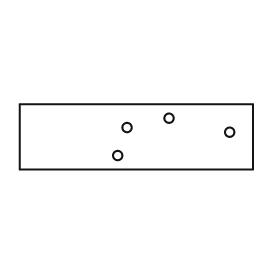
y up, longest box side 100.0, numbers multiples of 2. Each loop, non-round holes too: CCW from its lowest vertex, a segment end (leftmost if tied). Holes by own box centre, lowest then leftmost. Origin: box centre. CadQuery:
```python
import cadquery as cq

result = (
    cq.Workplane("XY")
    .moveTo(-50.0, -14.0)
    .lineTo(50.0, -14.0)
    .lineTo(50.0, 14.0)
    .lineTo(-50.0, 14.0)
    .close()
    .moveTo(-8.0, -8.0)
    .circle(2.0)
    .moveTo(40.0, 2.0)
    .circle(2.0)
    .moveTo(-4.0, 4.0)
    .circle(2.0)
    .moveTo(14.0, 8.0)
    .circle(2.0)
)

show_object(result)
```